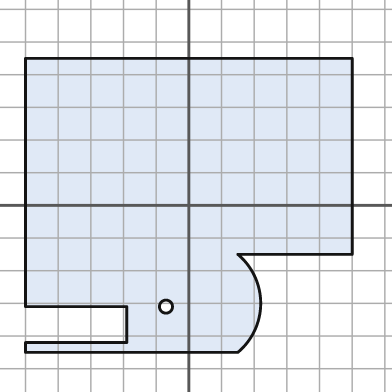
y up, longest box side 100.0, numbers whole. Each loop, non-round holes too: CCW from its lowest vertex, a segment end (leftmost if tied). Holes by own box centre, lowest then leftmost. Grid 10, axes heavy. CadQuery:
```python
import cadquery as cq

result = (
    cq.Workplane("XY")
    .moveTo(-50.0, -45.0)
    .lineTo(15.0, -45.0)
    .threePointArc((22.0, -30.0), (15.0, -15.0))
    .lineTo(50.0, -15.0)
    .lineTo(50.0, 45.0)
    .lineTo(-50.0, 45.0)
    .lineTo(-50.0, -31.0)
    .lineTo(-19.0, -31.0)
    .lineTo(-19.0, -42.0)
    .lineTo(-50.0, -42.0)
    .close()
    .moveTo(-7.0, -31.0)
    .circle(2.0)
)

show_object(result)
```